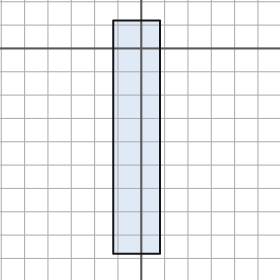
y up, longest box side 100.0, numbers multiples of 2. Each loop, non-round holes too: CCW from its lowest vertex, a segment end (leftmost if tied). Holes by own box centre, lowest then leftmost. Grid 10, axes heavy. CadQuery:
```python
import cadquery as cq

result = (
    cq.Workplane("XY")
    .moveTo(-12.0, -88.0)
    .lineTo(8.0, -88.0)
    .lineTo(8.0, 12.0)
    .lineTo(-12.0, 12.0)
    .close()
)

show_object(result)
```